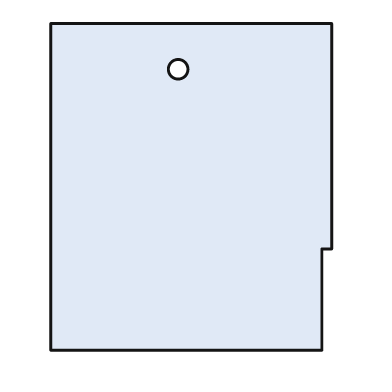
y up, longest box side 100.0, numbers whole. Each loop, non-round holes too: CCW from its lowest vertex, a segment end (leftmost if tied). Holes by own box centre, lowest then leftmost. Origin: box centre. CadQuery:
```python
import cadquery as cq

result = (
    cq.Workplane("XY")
    .moveTo(-43.0, -50.0)
    .lineTo(40.0, -50.0)
    .lineTo(40.0, -19.0)
    .lineTo(43.0, -19.0)
    .lineTo(43.0, 50.0)
    .lineTo(-43.0, 50.0)
    .close()
    .moveTo(-4.0, 36.0)
    .circle(3.0)
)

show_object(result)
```